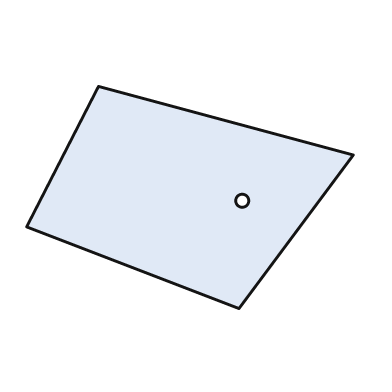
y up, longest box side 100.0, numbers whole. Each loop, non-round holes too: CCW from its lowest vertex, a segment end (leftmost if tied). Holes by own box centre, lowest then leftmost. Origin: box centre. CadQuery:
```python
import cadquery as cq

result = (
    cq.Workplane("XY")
    .moveTo(15.0, -34.0)
    .lineTo(50.0, 13.0)
    .lineTo(-28.0, 34.0)
    .lineTo(-50.0, -9.0)
    .close()
    .moveTo(16.0, -1.0)
    .circle(2.0)
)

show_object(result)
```